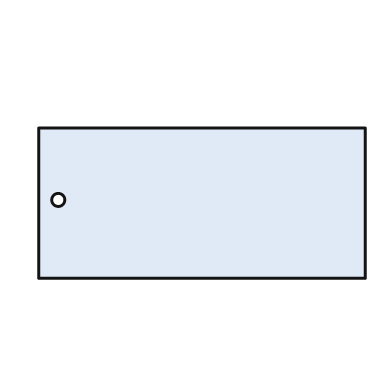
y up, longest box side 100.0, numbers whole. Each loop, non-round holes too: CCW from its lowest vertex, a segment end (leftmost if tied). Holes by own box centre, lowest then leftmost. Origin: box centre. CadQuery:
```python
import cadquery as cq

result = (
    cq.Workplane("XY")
    .moveTo(-50.0, -23.0)
    .lineTo(50.0, -23.0)
    .lineTo(50.0, 23.0)
    .lineTo(-50.0, 23.0)
    .close()
    .moveTo(-44.0, 1.0)
    .circle(2.0)
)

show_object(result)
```